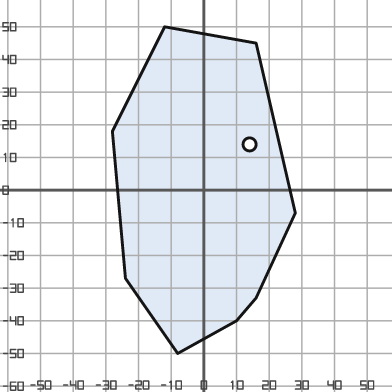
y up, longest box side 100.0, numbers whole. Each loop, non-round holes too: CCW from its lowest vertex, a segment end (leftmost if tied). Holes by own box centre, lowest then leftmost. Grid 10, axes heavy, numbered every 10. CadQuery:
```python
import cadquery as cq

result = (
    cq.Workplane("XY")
    .moveTo(-8.0, -50.0)
    .lineTo(10.0, -40.0)
    .lineTo(16.0, -33.0)
    .lineTo(28.0, -7.0)
    .lineTo(16.0, 45.0)
    .lineTo(-12.0, 50.0)
    .lineTo(-28.0, 18.0)
    .lineTo(-24.0, -27.0)
    .close()
    .moveTo(14.0, 14.0)
    .circle(2.0)
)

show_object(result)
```